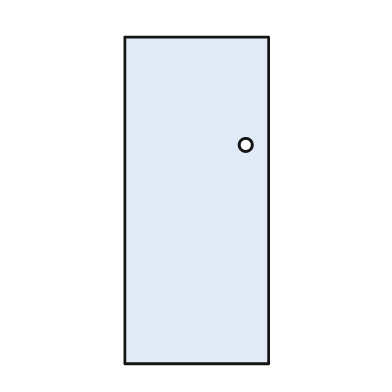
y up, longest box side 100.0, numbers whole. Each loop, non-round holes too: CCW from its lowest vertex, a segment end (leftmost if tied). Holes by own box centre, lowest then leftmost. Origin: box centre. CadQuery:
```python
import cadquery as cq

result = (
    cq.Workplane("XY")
    .moveTo(-22.0, -50.0)
    .lineTo(22.0, -50.0)
    .lineTo(22.0, 50.0)
    .lineTo(-22.0, 50.0)
    .close()
    .moveTo(15.0, 17.0)
    .circle(2.0)
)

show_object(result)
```